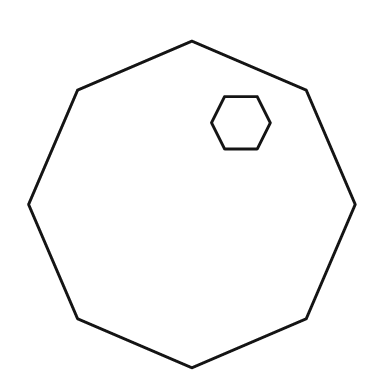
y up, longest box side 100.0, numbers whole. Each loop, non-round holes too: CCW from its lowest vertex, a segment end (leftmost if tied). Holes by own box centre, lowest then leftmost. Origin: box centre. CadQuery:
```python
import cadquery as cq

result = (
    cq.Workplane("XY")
    .moveTo(0.0, -50.0)
    .lineTo(35.0, -35.0)
    .lineTo(50.0, 0.0)
    .lineTo(35.0, 35.0)
    .lineTo(0.0, 50.0)
    .lineTo(-35.0, 35.0)
    .lineTo(-50.0, 0.0)
    .lineTo(-35.0, -35.0)
    .close()
    .moveTo(10.0, 17.0)
    .lineTo(20.0, 17.0)
    .lineTo(24.0, 25.0)
    .lineTo(20.0, 33.0)
    .lineTo(10.0, 33.0)
    .lineTo(6.0, 25.0)
    .close()
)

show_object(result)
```